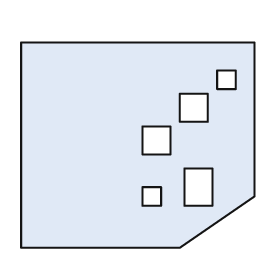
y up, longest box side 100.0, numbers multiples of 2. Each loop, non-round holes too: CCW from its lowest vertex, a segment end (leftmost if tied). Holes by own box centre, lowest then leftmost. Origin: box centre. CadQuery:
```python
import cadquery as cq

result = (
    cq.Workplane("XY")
    .moveTo(-50.0, -44.0)
    .lineTo(18.0, -44.0)
    .lineTo(50.0, -22.0)
    .lineTo(50.0, 44.0)
    .lineTo(-50.0, 44.0)
    .close()
    .moveTo(2.0, -26.0)
    .lineTo(10.0, -26.0)
    .lineTo(10.0, -18.0)
    .lineTo(2.0, -18.0)
    .close()
    .moveTo(20.0, -26.0)
    .lineTo(32.0, -26.0)
    .lineTo(32.0, -10.0)
    .lineTo(20.0, -10.0)
    .close()
    .moveTo(2.0, -4.0)
    .lineTo(14.0, -4.0)
    .lineTo(14.0, 8.0)
    .lineTo(2.0, 8.0)
    .close()
    .moveTo(18.0, 10.0)
    .lineTo(30.0, 10.0)
    .lineTo(30.0, 22.0)
    .lineTo(18.0, 22.0)
    .close()
    .moveTo(34.0, 24.0)
    .lineTo(42.0, 24.0)
    .lineTo(42.0, 32.0)
    .lineTo(34.0, 32.0)
    .close()
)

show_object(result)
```